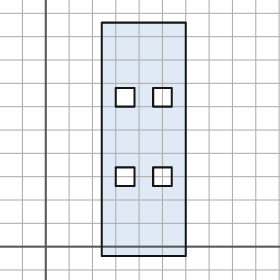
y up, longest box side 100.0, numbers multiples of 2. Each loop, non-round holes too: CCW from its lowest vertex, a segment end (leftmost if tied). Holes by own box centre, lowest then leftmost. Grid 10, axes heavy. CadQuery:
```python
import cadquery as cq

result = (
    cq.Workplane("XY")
    .moveTo(24.0, -4.0)
    .lineTo(60.0, -4.0)
    .lineTo(60.0, 96.0)
    .lineTo(24.0, 96.0)
    .close()
    .moveTo(30.0, 26.0)
    .lineTo(38.0, 26.0)
    .lineTo(38.0, 34.0)
    .lineTo(30.0, 34.0)
    .close()
    .moveTo(46.0, 26.0)
    .lineTo(54.0, 26.0)
    .lineTo(54.0, 34.0)
    .lineTo(46.0, 34.0)
    .close()
    .moveTo(30.0, 60.0)
    .lineTo(38.0, 60.0)
    .lineTo(38.0, 68.0)
    .lineTo(30.0, 68.0)
    .close()
    .moveTo(46.0, 60.0)
    .lineTo(54.0, 60.0)
    .lineTo(54.0, 68.0)
    .lineTo(46.0, 68.0)
    .close()
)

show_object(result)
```